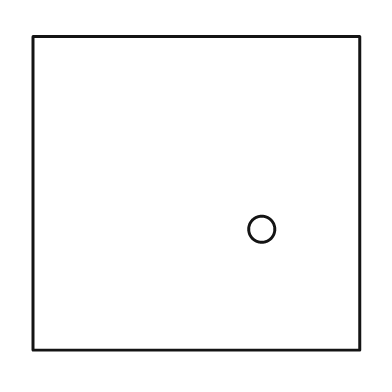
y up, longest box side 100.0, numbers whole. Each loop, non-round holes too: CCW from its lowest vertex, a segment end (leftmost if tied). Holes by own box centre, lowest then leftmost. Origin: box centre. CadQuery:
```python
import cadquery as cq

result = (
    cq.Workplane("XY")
    .moveTo(-50.0, -48.0)
    .lineTo(50.0, -48.0)
    .lineTo(50.0, 48.0)
    .lineTo(-50.0, 48.0)
    .close()
    .moveTo(20.0, -11.0)
    .circle(4.0)
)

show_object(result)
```